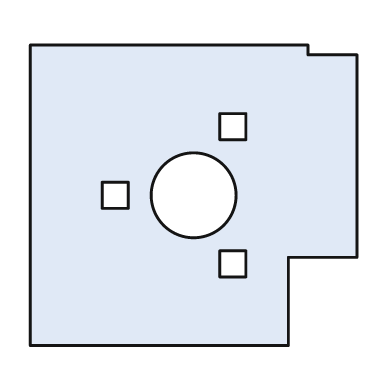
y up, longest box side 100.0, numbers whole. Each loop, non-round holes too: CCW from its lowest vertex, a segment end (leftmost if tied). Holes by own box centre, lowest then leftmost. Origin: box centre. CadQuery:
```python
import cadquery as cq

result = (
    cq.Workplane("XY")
    .moveTo(-50.0, -46.0)
    .lineTo(29.0, -46.0)
    .lineTo(29.0, -19.0)
    .lineTo(50.0, -19.0)
    .lineTo(50.0, 43.0)
    .lineTo(35.0, 43.0)
    .lineTo(35.0, 46.0)
    .lineTo(-50.0, 46.0)
    .close()
    .moveTo(8.0, -25.0)
    .lineTo(16.0, -25.0)
    .lineTo(16.0, -17.0)
    .lineTo(8.0, -17.0)
    .close()
    .moveTo(-28.0, -4.0)
    .lineTo(-20.0, -4.0)
    .lineTo(-20.0, 4.0)
    .lineTo(-28.0, 4.0)
    .close()
    .moveTo(0.0, 0.0)
    .circle(13.0)
    .moveTo(8.0, 17.0)
    .lineTo(16.0, 17.0)
    .lineTo(16.0, 25.0)
    .lineTo(8.0, 25.0)
    .close()
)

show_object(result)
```